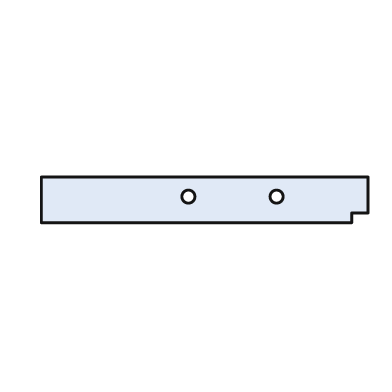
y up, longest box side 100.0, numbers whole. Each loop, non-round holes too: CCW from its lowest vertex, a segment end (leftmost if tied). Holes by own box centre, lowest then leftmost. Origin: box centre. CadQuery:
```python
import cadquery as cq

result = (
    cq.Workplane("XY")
    .moveTo(-50.0, -7.0)
    .lineTo(45.0, -7.0)
    .lineTo(45.0, -4.0)
    .lineTo(50.0, -4.0)
    .lineTo(50.0, 7.0)
    .lineTo(-50.0, 7.0)
    .close()
    .moveTo(-5.0, 1.0)
    .circle(2.0)
    .moveTo(22.0, 1.0)
    .circle(2.0)
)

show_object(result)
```